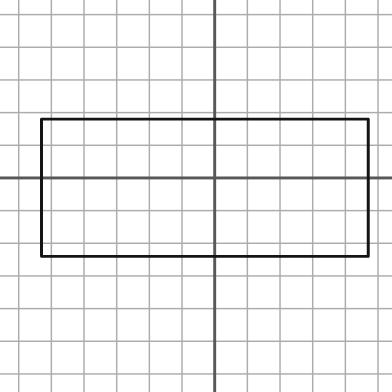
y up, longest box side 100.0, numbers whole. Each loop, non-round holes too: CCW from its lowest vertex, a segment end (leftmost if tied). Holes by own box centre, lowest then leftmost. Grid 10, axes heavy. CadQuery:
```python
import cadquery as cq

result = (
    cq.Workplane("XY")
    .moveTo(-53.0, -24.0)
    .lineTo(47.0, -24.0)
    .lineTo(47.0, 18.0)
    .lineTo(-53.0, 18.0)
    .close()
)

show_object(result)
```